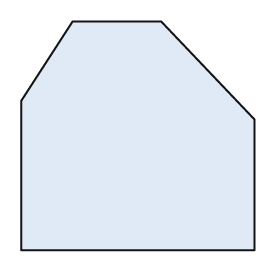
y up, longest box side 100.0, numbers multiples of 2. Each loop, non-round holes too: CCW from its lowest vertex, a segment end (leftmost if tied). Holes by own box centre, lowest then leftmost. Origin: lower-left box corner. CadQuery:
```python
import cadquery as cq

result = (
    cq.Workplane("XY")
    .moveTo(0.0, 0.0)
    .lineTo(100.0, 0.0)
    .lineTo(100.0, 56.0)
    .lineTo(60.0, 98.0)
    .lineTo(22.0, 98.0)
    .lineTo(0.0, 64.0)
    .close()
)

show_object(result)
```